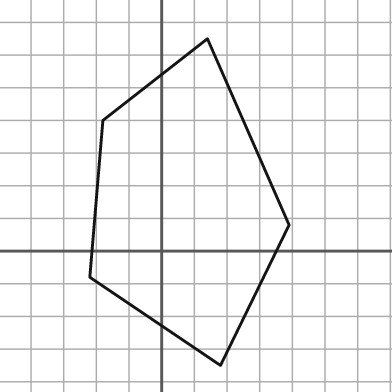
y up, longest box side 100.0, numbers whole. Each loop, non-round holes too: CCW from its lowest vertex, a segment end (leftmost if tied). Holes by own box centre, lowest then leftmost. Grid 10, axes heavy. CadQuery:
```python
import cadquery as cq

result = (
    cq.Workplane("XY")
    .moveTo(18.0, -35.0)
    .lineTo(39.0, 8.0)
    .lineTo(14.0, 65.0)
    .lineTo(-18.0, 40.0)
    .lineTo(-22.0, -8.0)
    .close()
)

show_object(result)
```